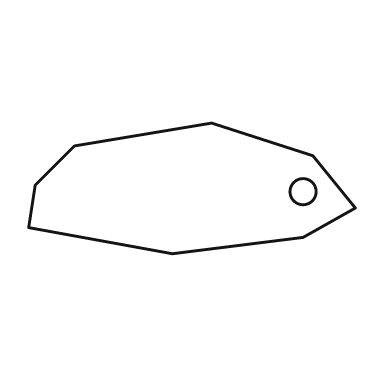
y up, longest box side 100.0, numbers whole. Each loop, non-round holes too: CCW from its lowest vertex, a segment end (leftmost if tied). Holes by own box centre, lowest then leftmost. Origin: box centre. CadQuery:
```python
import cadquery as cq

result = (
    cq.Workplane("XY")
    .moveTo(-6.0, -20.0)
    .lineTo(34.0, -15.0)
    .lineTo(50.0, -6.0)
    .lineTo(37.0, 10.0)
    .lineTo(6.0, 20.0)
    .lineTo(-36.0, 13.0)
    .lineTo(-48.0, 1.0)
    .lineTo(-50.0, -12.0)
    .close()
    .moveTo(34.0, -1.0)
    .circle(4.0)
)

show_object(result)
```